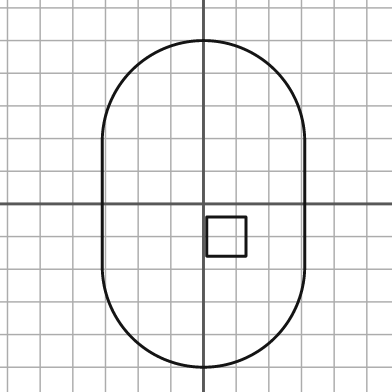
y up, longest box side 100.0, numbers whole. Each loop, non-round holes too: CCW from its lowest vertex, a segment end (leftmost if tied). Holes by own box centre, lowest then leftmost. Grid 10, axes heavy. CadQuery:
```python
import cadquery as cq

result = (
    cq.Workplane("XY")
    .moveTo(-31.0, -19.0)
    .threePointArc((0.0, -50.0), (31.0, -19.0))
    .lineTo(31.0, 19.0)
    .threePointArc((0.0, 50.0), (-31.0, 19.0))
    .close()
    .moveTo(1.0, -16.0)
    .lineTo(13.0, -16.0)
    .lineTo(13.0, -4.0)
    .lineTo(1.0, -4.0)
    .close()
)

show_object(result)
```